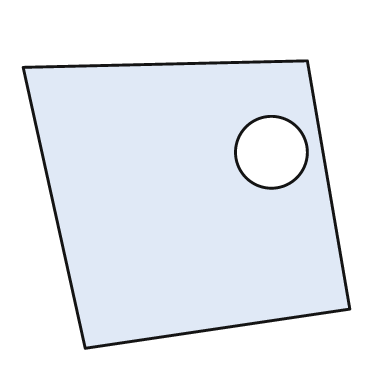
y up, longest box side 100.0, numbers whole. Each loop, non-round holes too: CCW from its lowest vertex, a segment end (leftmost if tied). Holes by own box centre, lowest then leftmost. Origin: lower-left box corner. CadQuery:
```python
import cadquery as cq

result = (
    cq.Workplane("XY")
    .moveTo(19.0, 0.0)
    .lineTo(100.0, 12.0)
    .lineTo(87.0, 88.0)
    .lineTo(0.0, 86.0)
    .close()
    .moveTo(76.0, 60.0)
    .circle(11.0)
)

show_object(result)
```